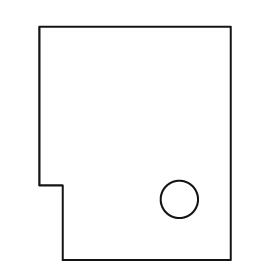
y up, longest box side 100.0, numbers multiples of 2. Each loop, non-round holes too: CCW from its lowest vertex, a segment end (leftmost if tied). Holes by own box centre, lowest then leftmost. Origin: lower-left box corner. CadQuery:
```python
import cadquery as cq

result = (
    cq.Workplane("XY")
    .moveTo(10.0, 0.0)
    .lineTo(82.0, 0.0)
    .lineTo(82.0, 100.0)
    .lineTo(0.0, 100.0)
    .lineTo(0.0, 32.0)
    .lineTo(10.0, 32.0)
    .close()
    .moveTo(60.0, 26.0)
    .circle(8.0)
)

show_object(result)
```